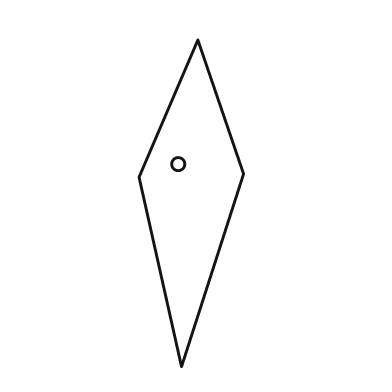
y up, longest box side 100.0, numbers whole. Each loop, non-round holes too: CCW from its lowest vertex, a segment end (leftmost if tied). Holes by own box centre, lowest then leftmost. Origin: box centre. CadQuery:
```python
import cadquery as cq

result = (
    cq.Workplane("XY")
    .moveTo(-3.0, -50.0)
    .lineTo(16.0, 9.0)
    .lineTo(2.0, 50.0)
    .lineTo(-16.0, 8.0)
    .close()
    .moveTo(-4.0, 12.0)
    .circle(2.0)
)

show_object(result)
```